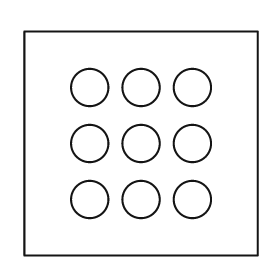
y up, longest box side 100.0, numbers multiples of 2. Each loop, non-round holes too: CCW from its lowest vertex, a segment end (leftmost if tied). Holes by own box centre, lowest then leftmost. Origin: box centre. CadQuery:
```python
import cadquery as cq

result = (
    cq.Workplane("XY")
    .moveTo(-50.0, -48.0)
    .lineTo(50.0, -48.0)
    .lineTo(50.0, 48.0)
    .lineTo(-50.0, 48.0)
    .close()
    .moveTo(-22.0, -24.0)
    .circle(8.0)
    .moveTo(0.0, -24.0)
    .circle(8.0)
    .moveTo(22.0, -24.0)
    .circle(8.0)
    .moveTo(-22.0, 0.0)
    .circle(8.0)
    .moveTo(0.0, 0.0)
    .circle(8.0)
    .moveTo(22.0, 0.0)
    .circle(8.0)
    .moveTo(-22.0, 24.0)
    .circle(8.0)
    .moveTo(0.0, 24.0)
    .circle(8.0)
    .moveTo(22.0, 24.0)
    .circle(8.0)
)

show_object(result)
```